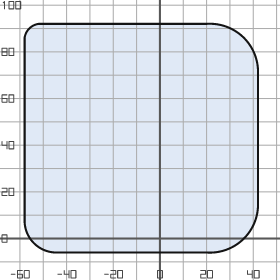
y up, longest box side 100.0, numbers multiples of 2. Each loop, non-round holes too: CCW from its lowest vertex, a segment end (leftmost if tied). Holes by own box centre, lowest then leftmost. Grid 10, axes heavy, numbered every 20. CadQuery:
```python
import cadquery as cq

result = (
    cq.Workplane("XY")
    .moveTo(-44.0, -6.0)
    .lineTo(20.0, -6.0)
    .threePointArc((36.0, 0.0), (42.0, 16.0))
    .lineTo(42.0, 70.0)
    .threePointArc((36.0, 86.0), (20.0, 92.0))
    .lineTo(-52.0, 92.0)
    .threePointArc((-56.0, 90.0), (-58.0, 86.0))
    .lineTo(-58.0, 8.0)
    .threePointArc((-54.0, -2.0), (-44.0, -6.0))
    .close()
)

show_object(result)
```